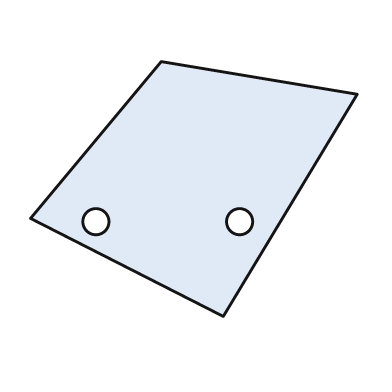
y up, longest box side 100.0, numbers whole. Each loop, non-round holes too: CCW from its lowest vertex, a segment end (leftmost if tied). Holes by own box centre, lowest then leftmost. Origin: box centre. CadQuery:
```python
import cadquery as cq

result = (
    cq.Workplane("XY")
    .moveTo(9.0, -39.0)
    .lineTo(50.0, 29.0)
    .lineTo(-10.0, 39.0)
    .lineTo(-50.0, -9.0)
    .close()
    .moveTo(-30.0, -10.0)
    .circle(4.0)
    .moveTo(14.0, -10.0)
    .circle(4.0)
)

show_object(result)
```